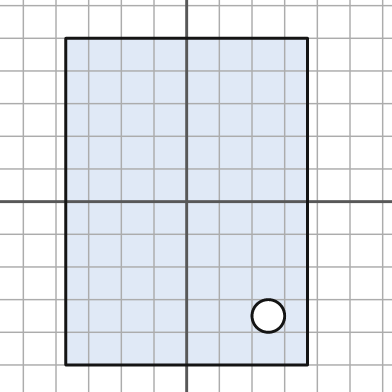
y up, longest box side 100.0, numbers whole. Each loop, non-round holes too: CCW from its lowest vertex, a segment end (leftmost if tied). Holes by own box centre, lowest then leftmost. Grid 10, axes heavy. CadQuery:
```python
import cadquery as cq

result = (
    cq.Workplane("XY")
    .moveTo(-37.0, -50.0)
    .lineTo(37.0, -50.0)
    .lineTo(37.0, 50.0)
    .lineTo(-37.0, 50.0)
    .close()
    .moveTo(25.0, -35.0)
    .circle(5.0)
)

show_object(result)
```